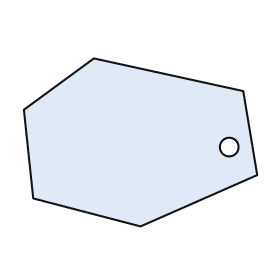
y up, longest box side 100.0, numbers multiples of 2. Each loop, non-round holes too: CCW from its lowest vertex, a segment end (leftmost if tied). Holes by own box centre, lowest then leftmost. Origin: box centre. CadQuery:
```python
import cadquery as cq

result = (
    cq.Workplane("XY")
    .moveTo(0.0, -36.0)
    .lineTo(50.0, -14.0)
    .lineTo(44.0, 22.0)
    .lineTo(-20.0, 36.0)
    .lineTo(-50.0, 14.0)
    .lineTo(-46.0, -24.0)
    .close()
    .moveTo(38.0, -2.0)
    .circle(4.0)
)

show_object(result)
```